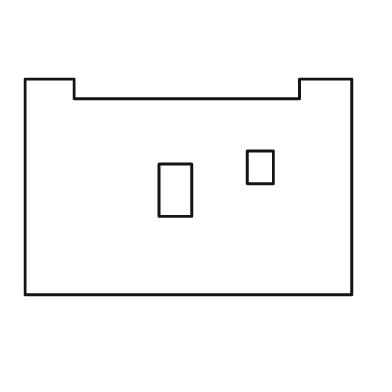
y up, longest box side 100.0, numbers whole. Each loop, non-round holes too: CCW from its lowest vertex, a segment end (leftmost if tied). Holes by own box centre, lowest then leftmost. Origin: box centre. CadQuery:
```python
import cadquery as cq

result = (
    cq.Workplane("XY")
    .moveTo(-50.0, -33.0)
    .lineTo(50.0, -33.0)
    .lineTo(50.0, 33.0)
    .lineTo(34.0, 33.0)
    .lineTo(34.0, 27.0)
    .lineTo(-35.0, 27.0)
    .lineTo(-35.0, 33.0)
    .lineTo(-50.0, 33.0)
    .close()
    .moveTo(-9.0, -9.0)
    .lineTo(1.0, -9.0)
    .lineTo(1.0, 7.0)
    .lineTo(-9.0, 7.0)
    .close()
    .moveTo(18.0, 1.0)
    .lineTo(26.0, 1.0)
    .lineTo(26.0, 11.0)
    .lineTo(18.0, 11.0)
    .close()
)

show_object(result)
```